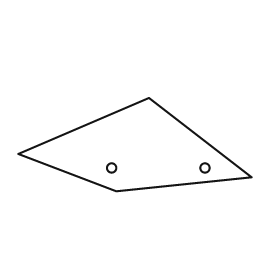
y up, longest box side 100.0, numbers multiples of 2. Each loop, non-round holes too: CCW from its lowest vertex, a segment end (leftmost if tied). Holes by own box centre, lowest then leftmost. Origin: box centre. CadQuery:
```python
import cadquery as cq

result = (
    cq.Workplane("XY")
    .moveTo(-8.0, -20.0)
    .lineTo(50.0, -14.0)
    .lineTo(6.0, 20.0)
    .lineTo(-50.0, -4.0)
    .close()
    .moveTo(-10.0, -10.0)
    .circle(2.0)
    .moveTo(30.0, -10.0)
    .circle(2.0)
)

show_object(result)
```